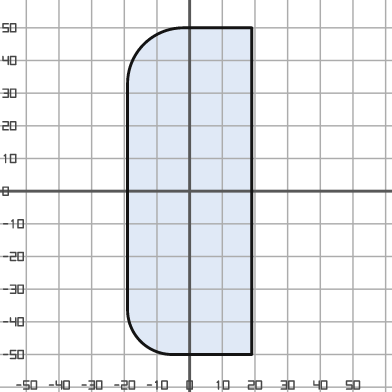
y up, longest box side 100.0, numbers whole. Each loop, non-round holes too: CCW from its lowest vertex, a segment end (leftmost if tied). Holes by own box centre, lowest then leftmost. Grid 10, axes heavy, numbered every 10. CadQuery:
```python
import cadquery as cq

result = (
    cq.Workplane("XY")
    .moveTo(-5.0, -50.0)
    .lineTo(19.0, -50.0)
    .lineTo(19.0, 50.0)
    .lineTo(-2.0, 50.0)
    .threePointArc((-14.0, 45.0), (-19.0, 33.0))
    .lineTo(-19.0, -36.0)
    .threePointArc((-15.0, -46.0), (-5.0, -50.0))
    .close()
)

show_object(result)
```